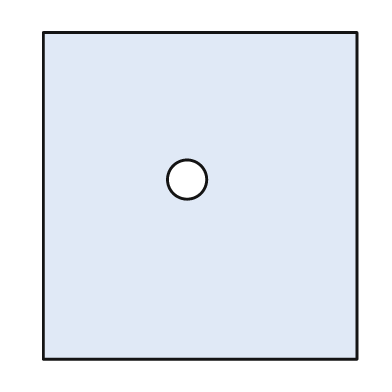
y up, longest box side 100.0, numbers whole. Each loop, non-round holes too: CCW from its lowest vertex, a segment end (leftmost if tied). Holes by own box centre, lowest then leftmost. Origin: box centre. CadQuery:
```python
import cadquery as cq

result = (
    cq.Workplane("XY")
    .moveTo(-48.0, -50.0)
    .lineTo(48.0, -50.0)
    .lineTo(48.0, 50.0)
    .lineTo(-48.0, 50.0)
    .close()
    .moveTo(-4.0, 5.0)
    .circle(6.0)
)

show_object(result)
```